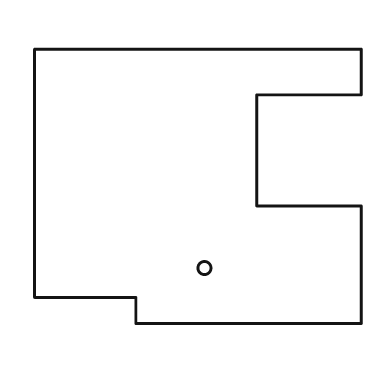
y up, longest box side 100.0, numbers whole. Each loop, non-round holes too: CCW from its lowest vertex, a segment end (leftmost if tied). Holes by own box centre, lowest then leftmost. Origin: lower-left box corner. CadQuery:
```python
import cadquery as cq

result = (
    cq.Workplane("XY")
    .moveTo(31.0, 0.0)
    .lineTo(100.0, 0.0)
    .lineTo(100.0, 36.0)
    .lineTo(68.0, 36.0)
    .lineTo(68.0, 70.0)
    .lineTo(100.0, 70.0)
    .lineTo(100.0, 84.0)
    .lineTo(0.0, 84.0)
    .lineTo(0.0, 8.0)
    .lineTo(31.0, 8.0)
    .close()
    .moveTo(52.0, 17.0)
    .circle(2.0)
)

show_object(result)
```